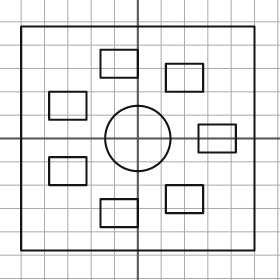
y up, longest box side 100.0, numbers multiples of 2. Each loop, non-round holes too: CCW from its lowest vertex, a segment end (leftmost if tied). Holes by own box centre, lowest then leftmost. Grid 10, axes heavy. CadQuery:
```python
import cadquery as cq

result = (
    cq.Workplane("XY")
    .moveTo(-50.0, -48.0)
    .lineTo(50.0, -48.0)
    .lineTo(50.0, 48.0)
    .lineTo(-50.0, 48.0)
    .close()
    .moveTo(-16.0, -38.0)
    .lineTo(0.0, -38.0)
    .lineTo(0.0, -26.0)
    .lineTo(-16.0, -26.0)
    .close()
    .moveTo(12.0, -32.0)
    .lineTo(28.0, -32.0)
    .lineTo(28.0, -20.0)
    .lineTo(12.0, -20.0)
    .close()
    .moveTo(-38.0, -20.0)
    .lineTo(-22.0, -20.0)
    .lineTo(-22.0, -8.0)
    .lineTo(-38.0, -8.0)
    .close()
    .moveTo(0.0, 0.0)
    .circle(14.0)
    .moveTo(26.0, -6.0)
    .lineTo(42.0, -6.0)
    .lineTo(42.0, 6.0)
    .lineTo(26.0, 6.0)
    .close()
    .moveTo(-38.0, 8.0)
    .lineTo(-22.0, 8.0)
    .lineTo(-22.0, 20.0)
    .lineTo(-38.0, 20.0)
    .close()
    .moveTo(12.0, 20.0)
    .lineTo(28.0, 20.0)
    .lineTo(28.0, 32.0)
    .lineTo(12.0, 32.0)
    .close()
    .moveTo(-16.0, 26.0)
    .lineTo(0.0, 26.0)
    .lineTo(0.0, 38.0)
    .lineTo(-16.0, 38.0)
    .close()
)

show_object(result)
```